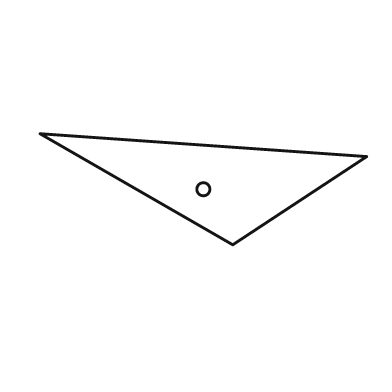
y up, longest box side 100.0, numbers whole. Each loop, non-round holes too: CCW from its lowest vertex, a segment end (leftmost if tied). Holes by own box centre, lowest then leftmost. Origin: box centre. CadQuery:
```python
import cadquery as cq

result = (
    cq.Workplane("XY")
    .moveTo(9.0, -17.0)
    .lineTo(50.0, 10.0)
    .lineTo(-50.0, 17.0)
    .close()
    .moveTo(0.0, 0.0)
    .circle(2.0)
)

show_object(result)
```